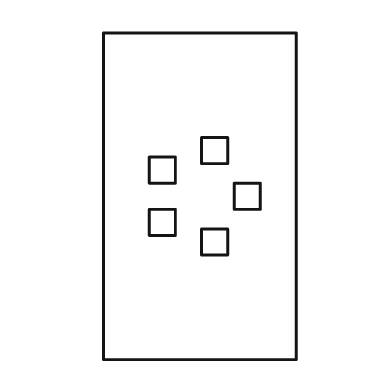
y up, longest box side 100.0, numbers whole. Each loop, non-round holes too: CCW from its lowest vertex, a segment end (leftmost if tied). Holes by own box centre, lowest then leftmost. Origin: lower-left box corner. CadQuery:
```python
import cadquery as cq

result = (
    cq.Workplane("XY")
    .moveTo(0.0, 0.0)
    .lineTo(59.0, 0.0)
    .lineTo(59.0, 100.0)
    .lineTo(0.0, 100.0)
    .close()
    .moveTo(30.0, 32.0)
    .lineTo(38.0, 32.0)
    .lineTo(38.0, 40.0)
    .lineTo(30.0, 40.0)
    .close()
    .moveTo(14.0, 38.0)
    .lineTo(22.0, 38.0)
    .lineTo(22.0, 46.0)
    .lineTo(14.0, 46.0)
    .close()
    .moveTo(40.0, 46.0)
    .lineTo(48.0, 46.0)
    .lineTo(48.0, 54.0)
    .lineTo(40.0, 54.0)
    .close()
    .moveTo(14.0, 54.0)
    .lineTo(22.0, 54.0)
    .lineTo(22.0, 62.0)
    .lineTo(14.0, 62.0)
    .close()
    .moveTo(30.0, 60.0)
    .lineTo(38.0, 60.0)
    .lineTo(38.0, 68.0)
    .lineTo(30.0, 68.0)
    .close()
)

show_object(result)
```